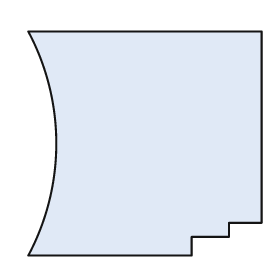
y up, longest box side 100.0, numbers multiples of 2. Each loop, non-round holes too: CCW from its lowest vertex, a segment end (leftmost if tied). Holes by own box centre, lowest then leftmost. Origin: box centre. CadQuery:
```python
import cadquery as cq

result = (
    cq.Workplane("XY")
    .moveTo(-50.0, -48.0)
    .lineTo(20.0, -48.0)
    .lineTo(20.0, -40.0)
    .lineTo(36.0, -40.0)
    .lineTo(36.0, -34.0)
    .lineTo(50.0, -34.0)
    .lineTo(50.0, 48.0)
    .lineTo(-50.0, 48.0)
    .threePointArc((-38.0, 0.0), (-50.0, -48.0))
    .close()
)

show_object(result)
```